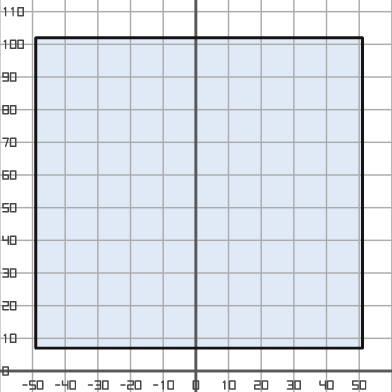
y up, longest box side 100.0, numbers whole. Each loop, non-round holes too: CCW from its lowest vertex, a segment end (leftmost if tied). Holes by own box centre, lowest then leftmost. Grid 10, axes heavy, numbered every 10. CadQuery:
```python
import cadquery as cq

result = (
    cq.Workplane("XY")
    .moveTo(-49.0, 7.0)
    .lineTo(51.0, 7.0)
    .lineTo(51.0, 102.0)
    .lineTo(-49.0, 102.0)
    .close()
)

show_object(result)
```